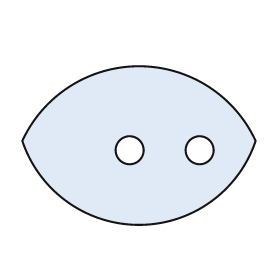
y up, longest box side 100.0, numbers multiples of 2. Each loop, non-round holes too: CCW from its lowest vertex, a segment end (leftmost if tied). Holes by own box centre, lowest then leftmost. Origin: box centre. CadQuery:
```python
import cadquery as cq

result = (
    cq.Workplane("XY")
    .moveTo(-50.0, 2.0)
    .threePointArc((0.0, -34.0), (50.0, 2.0))
    .threePointArc((0.0, 34.0), (-50.0, 2.0))
    .close()
    .moveTo(-4.0, -2.0)
    .circle(6.0)
    .moveTo(26.0, -2.0)
    .circle(6.0)
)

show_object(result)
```